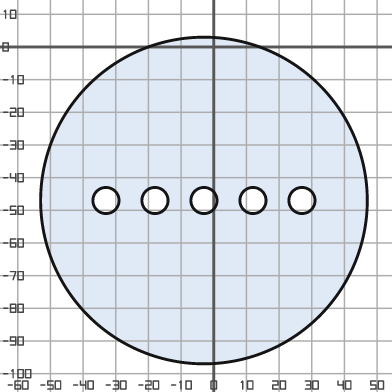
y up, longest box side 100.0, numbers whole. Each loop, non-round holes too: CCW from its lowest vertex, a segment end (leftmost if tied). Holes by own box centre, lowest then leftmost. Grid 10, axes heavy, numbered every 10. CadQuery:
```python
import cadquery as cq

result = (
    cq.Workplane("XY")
    .moveTo(-3.0, -47.0)
    .circle(50.0)
    .moveTo(-33.0, -47.0)
    .circle(4.0)
    .moveTo(-18.0, -47.0)
    .circle(4.0)
    .moveTo(-3.0, -47.0)
    .circle(4.0)
    .moveTo(12.0, -47.0)
    .circle(4.0)
    .moveTo(27.0, -47.0)
    .circle(4.0)
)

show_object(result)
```